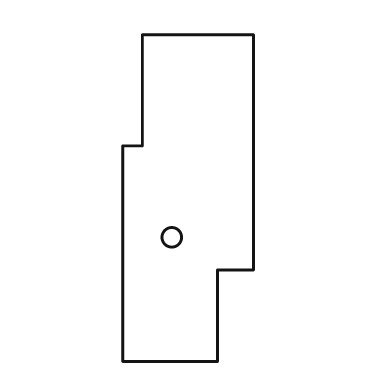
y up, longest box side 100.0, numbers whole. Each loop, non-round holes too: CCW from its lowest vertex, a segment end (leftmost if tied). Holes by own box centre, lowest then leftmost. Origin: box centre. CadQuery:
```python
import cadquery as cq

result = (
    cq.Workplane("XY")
    .moveTo(-20.0, -50.0)
    .lineTo(9.0, -50.0)
    .lineTo(9.0, -22.0)
    .lineTo(20.0, -22.0)
    .lineTo(20.0, 50.0)
    .lineTo(-14.0, 50.0)
    .lineTo(-14.0, 16.0)
    .lineTo(-20.0, 16.0)
    .close()
    .moveTo(-5.0, -12.0)
    .circle(3.0)
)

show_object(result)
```